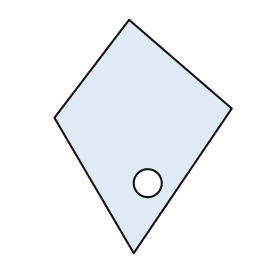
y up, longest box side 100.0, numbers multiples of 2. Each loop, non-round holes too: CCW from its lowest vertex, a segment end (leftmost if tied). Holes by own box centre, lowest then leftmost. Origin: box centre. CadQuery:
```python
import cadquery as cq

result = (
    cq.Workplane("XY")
    .moveTo(-4.0, -50.0)
    .lineTo(38.0, 12.0)
    .lineTo(-6.0, 50.0)
    .lineTo(-38.0, 8.0)
    .close()
    .moveTo(2.0, -20.0)
    .circle(6.0)
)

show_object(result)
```